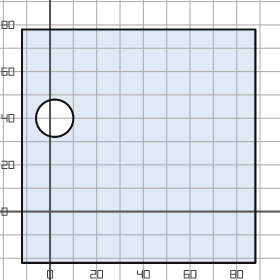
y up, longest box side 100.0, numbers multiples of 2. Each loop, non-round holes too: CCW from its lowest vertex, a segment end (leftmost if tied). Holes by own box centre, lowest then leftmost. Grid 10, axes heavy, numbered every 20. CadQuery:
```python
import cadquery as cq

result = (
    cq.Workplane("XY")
    .moveTo(-12.0, -22.0)
    .lineTo(88.0, -22.0)
    .lineTo(88.0, 78.0)
    .lineTo(-12.0, 78.0)
    .close()
    .moveTo(2.0, 40.0)
    .circle(8.0)
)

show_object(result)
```